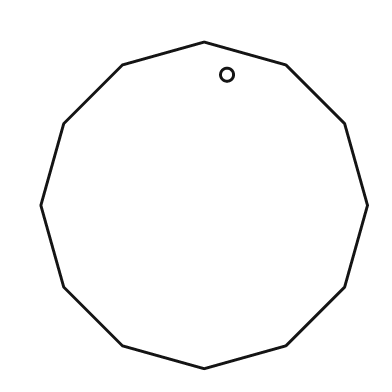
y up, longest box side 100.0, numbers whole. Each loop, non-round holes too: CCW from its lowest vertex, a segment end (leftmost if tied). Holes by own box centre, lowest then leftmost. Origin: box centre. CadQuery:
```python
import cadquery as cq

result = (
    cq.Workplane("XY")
    .moveTo(0.0, -50.0)
    .lineTo(25.0, -43.0)
    .lineTo(43.0, -25.0)
    .lineTo(50.0, 0.0)
    .lineTo(43.0, 25.0)
    .lineTo(25.0, 43.0)
    .lineTo(0.0, 50.0)
    .lineTo(-25.0, 43.0)
    .lineTo(-43.0, 25.0)
    .lineTo(-50.0, 0.0)
    .lineTo(-43.0, -25.0)
    .lineTo(-25.0, -43.0)
    .close()
    .moveTo(7.0, 40.0)
    .circle(2.0)
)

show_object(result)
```